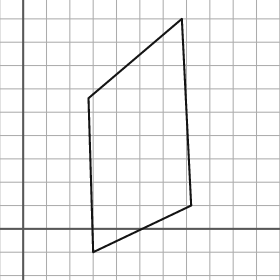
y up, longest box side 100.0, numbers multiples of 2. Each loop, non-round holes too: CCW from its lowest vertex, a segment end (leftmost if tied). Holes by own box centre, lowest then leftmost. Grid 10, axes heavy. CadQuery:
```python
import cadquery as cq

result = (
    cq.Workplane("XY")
    .moveTo(30.0, -10.0)
    .lineTo(72.0, 10.0)
    .lineTo(68.0, 90.0)
    .lineTo(28.0, 56.0)
    .close()
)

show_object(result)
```